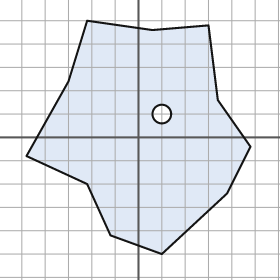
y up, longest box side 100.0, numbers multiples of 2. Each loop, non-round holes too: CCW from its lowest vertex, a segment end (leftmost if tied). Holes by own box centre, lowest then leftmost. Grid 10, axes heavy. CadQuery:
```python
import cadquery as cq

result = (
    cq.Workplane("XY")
    .moveTo(10.0, -50.0)
    .lineTo(38.0, -24.0)
    .lineTo(48.0, -4.0)
    .lineTo(34.0, 16.0)
    .lineTo(30.0, 48.0)
    .lineTo(6.0, 46.0)
    .lineTo(-22.0, 50.0)
    .lineTo(-30.0, 24.0)
    .lineTo(-48.0, -8.0)
    .lineTo(-22.0, -20.0)
    .lineTo(-12.0, -42.0)
    .close()
    .moveTo(10.0, 10.0)
    .circle(4.0)
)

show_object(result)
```